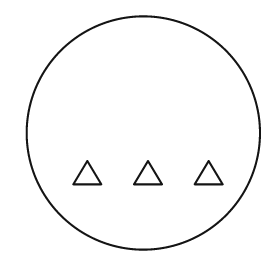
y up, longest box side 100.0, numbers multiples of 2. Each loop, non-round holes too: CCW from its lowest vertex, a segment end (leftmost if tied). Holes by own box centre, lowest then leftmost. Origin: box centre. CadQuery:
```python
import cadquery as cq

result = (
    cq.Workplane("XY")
    .moveTo(0.0, 0.0)
    .circle(50.0)
    .moveTo(-30.0, -22.0)
    .lineTo(-18.0, -22.0)
    .lineTo(-24.0, -12.0)
    .close()
    .moveTo(-4.0, -22.0)
    .lineTo(8.0, -22.0)
    .lineTo(2.0, -12.0)
    .close()
    .moveTo(22.0, -22.0)
    .lineTo(34.0, -22.0)
    .lineTo(28.0, -12.0)
    .close()
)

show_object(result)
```